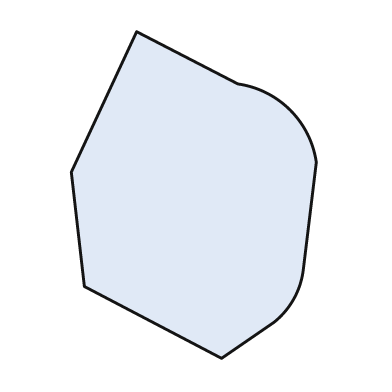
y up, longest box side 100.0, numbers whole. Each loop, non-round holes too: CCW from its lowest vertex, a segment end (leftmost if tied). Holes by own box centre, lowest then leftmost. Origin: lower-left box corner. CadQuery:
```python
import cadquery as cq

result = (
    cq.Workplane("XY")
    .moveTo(46.0, 0.0)
    .lineTo(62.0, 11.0)
    .threePointArc((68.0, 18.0), (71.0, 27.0))
    .lineTo(75.0, 60.0)
    .threePointArc((67.0, 76.0), (51.0, 84.0))
    .lineTo(20.0, 100.0)
    .lineTo(0.0, 57.0)
    .lineTo(4.0, 22.0)
    .close()
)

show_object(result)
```